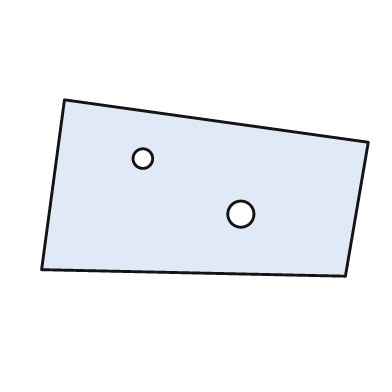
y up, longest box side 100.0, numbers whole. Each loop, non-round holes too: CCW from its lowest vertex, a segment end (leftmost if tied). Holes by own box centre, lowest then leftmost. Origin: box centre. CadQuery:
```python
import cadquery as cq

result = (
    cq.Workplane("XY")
    .moveTo(43.0, -27.0)
    .lineTo(50.0, 14.0)
    .lineTo(-43.0, 27.0)
    .lineTo(-50.0, -25.0)
    .close()
    .moveTo(11.0, -8.0)
    .circle(4.0)
    .moveTo(-19.0, 9.0)
    .circle(3.0)
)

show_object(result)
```